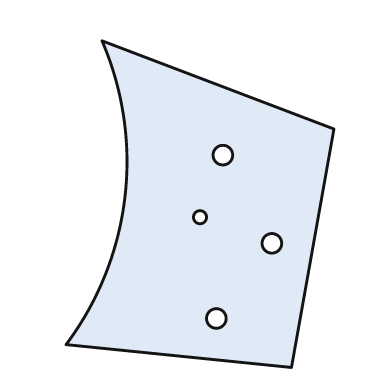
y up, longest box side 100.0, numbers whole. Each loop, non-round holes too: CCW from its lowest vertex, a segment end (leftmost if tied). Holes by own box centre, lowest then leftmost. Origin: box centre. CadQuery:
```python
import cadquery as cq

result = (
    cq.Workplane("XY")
    .moveTo(28.0, -50.0)
    .lineTo(41.0, 23.0)
    .lineTo(-30.0, 50.0)
    .threePointArc((-23.0, 2.0), (-41.0, -43.0))
    .close()
    .moveTo(5.0, -35.0)
    .circle(3.0)
    .moveTo(22.0, -12.0)
    .circle(3.0)
    .moveTo(0.0, -4.0)
    .circle(2.0)
    .moveTo(7.0, 15.0)
    .circle(3.0)
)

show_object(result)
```